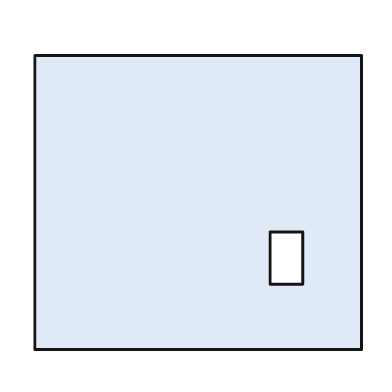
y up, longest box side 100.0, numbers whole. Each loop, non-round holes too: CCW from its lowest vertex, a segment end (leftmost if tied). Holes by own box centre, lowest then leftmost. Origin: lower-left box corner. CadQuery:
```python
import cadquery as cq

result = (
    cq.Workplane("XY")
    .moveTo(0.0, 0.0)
    .lineTo(100.0, 0.0)
    .lineTo(100.0, 90.0)
    .lineTo(0.0, 90.0)
    .close()
    .moveTo(72.0, 20.0)
    .lineTo(82.0, 20.0)
    .lineTo(82.0, 36.0)
    .lineTo(72.0, 36.0)
    .close()
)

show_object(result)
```